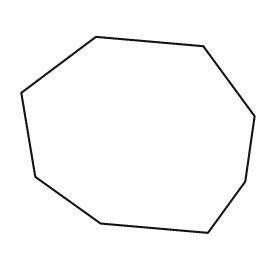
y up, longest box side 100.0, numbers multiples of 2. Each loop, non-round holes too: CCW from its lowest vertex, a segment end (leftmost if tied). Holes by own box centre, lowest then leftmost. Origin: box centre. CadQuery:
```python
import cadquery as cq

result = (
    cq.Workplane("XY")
    .moveTo(30.0, -42.0)
    .lineTo(46.0, -20.0)
    .lineTo(50.0, 8.0)
    .lineTo(28.0, 38.0)
    .lineTo(-18.0, 42.0)
    .lineTo(-50.0, 18.0)
    .lineTo(-44.0, -18.0)
    .lineTo(-16.0, -38.0)
    .close()
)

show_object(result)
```